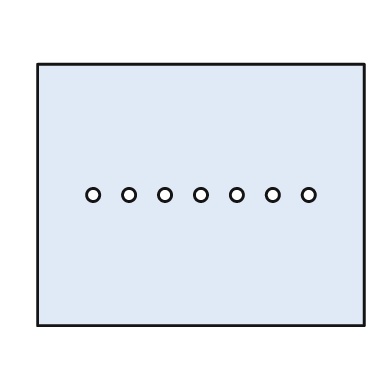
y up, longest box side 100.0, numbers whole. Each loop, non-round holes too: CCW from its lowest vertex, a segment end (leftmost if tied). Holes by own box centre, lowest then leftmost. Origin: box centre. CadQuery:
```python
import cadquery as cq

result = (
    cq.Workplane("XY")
    .moveTo(-50.0, -40.0)
    .lineTo(50.0, -40.0)
    .lineTo(50.0, 40.0)
    .lineTo(-50.0, 40.0)
    .close()
    .moveTo(-33.0, 0.0)
    .circle(2.0)
    .moveTo(-22.0, 0.0)
    .circle(2.0)
    .moveTo(-11.0, 0.0)
    .circle(2.0)
    .moveTo(0.0, 0.0)
    .circle(2.0)
    .moveTo(11.0, 0.0)
    .circle(2.0)
    .moveTo(22.0, 0.0)
    .circle(2.0)
    .moveTo(33.0, 0.0)
    .circle(2.0)
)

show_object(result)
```